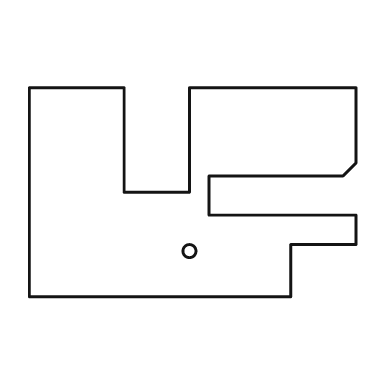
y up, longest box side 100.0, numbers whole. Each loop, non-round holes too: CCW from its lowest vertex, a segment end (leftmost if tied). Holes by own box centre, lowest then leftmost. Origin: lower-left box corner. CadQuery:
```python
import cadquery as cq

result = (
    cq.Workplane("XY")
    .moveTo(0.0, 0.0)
    .lineTo(80.0, 0.0)
    .lineTo(80.0, 16.0)
    .lineTo(100.0, 16.0)
    .lineTo(100.0, 25.0)
    .lineTo(55.0, 25.0)
    .lineTo(55.0, 37.0)
    .lineTo(96.0, 37.0)
    .lineTo(100.0, 41.0)
    .lineTo(100.0, 64.0)
    .lineTo(49.0, 64.0)
    .lineTo(49.0, 32.0)
    .lineTo(29.0, 32.0)
    .lineTo(29.0, 64.0)
    .lineTo(0.0, 64.0)
    .close()
    .moveTo(49.0, 14.0)
    .circle(2.0)
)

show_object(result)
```